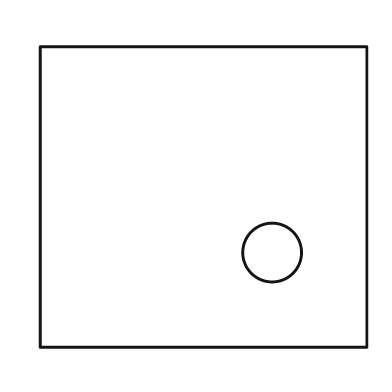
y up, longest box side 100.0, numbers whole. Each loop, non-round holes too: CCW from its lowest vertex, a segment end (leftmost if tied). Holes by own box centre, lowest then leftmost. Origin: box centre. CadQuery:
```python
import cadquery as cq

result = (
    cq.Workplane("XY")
    .moveTo(-50.0, -46.0)
    .lineTo(50.0, -46.0)
    .lineTo(50.0, 46.0)
    .lineTo(-50.0, 46.0)
    .close()
    .moveTo(21.0, -17.0)
    .circle(9.0)
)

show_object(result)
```